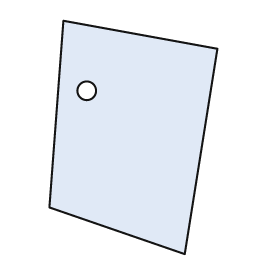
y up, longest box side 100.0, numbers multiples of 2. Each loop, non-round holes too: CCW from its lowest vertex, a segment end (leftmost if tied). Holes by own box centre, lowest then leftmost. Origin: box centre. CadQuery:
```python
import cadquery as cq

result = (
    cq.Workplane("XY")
    .moveTo(22.0, -50.0)
    .lineTo(36.0, 38.0)
    .lineTo(-30.0, 50.0)
    .lineTo(-36.0, -30.0)
    .close()
    .moveTo(-20.0, 20.0)
    .circle(4.0)
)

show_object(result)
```